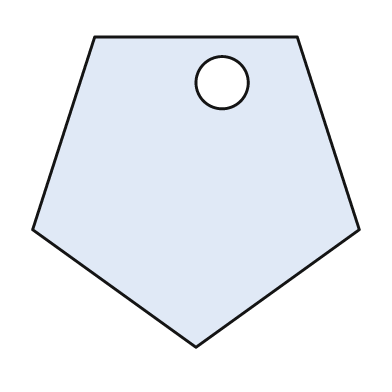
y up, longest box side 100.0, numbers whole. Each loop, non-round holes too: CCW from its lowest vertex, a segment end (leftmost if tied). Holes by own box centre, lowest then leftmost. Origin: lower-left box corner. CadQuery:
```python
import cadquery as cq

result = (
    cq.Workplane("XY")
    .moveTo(50.0, 0.0)
    .lineTo(100.0, 36.0)
    .lineTo(81.0, 95.0)
    .lineTo(19.0, 95.0)
    .lineTo(0.0, 36.0)
    .close()
    .moveTo(58.0, 81.0)
    .circle(8.0)
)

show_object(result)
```